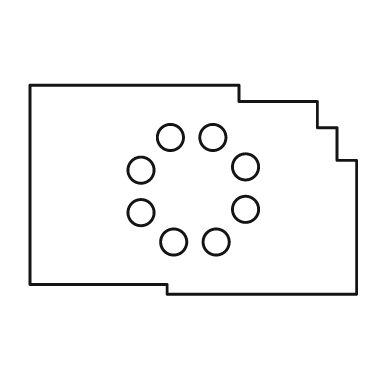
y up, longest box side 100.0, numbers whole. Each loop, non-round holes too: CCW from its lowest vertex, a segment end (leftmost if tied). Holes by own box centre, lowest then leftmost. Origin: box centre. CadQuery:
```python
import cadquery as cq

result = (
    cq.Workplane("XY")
    .moveTo(-8.0, -32.0)
    .lineTo(50.0, -32.0)
    .lineTo(50.0, 9.0)
    .lineTo(44.0, 9.0)
    .lineTo(44.0, 19.0)
    .lineTo(38.0, 19.0)
    .lineTo(38.0, 27.0)
    .lineTo(14.0, 27.0)
    .lineTo(14.0, 32.0)
    .lineTo(-50.0, 32.0)
    .lineTo(-50.0, -29.0)
    .lineTo(-8.0, -29.0)
    .close()
    .moveTo(-6.0, -16.0)
    .circle(4.0)
    .moveTo(7.0, -16.0)
    .circle(4.0)
    .moveTo(-16.0, -7.0)
    .circle(4.0)
    .moveTo(16.0, -6.0)
    .circle(4.0)
    .moveTo(-16.0, 6.0)
    .circle(4.0)
    .moveTo(16.0, 7.0)
    .circle(4.0)
    .moveTo(-7.0, 16.0)
    .circle(4.0)
    .moveTo(6.0, 16.0)
    .circle(4.0)
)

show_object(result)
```